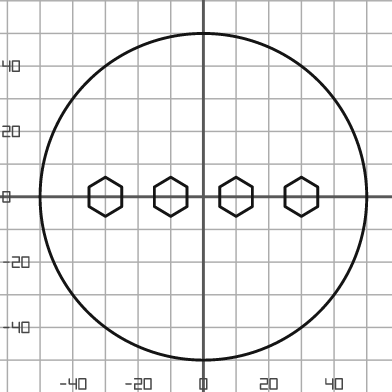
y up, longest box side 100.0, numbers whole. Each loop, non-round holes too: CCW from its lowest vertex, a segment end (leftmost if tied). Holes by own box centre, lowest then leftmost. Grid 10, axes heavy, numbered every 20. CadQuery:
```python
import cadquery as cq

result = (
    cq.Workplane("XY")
    .moveTo(0.0, 0.0)
    .circle(50.0)
    .moveTo(-30.0, -6.0)
    .lineTo(-25.0, -3.0)
    .lineTo(-25.0, 3.0)
    .lineTo(-30.0, 6.0)
    .lineTo(-35.0, 3.0)
    .lineTo(-35.0, -3.0)
    .close()
    .moveTo(-10.0, -6.0)
    .lineTo(-5.0, -3.0)
    .lineTo(-5.0, 3.0)
    .lineTo(-10.0, 6.0)
    .lineTo(-15.0, 3.0)
    .lineTo(-15.0, -3.0)
    .close()
    .moveTo(10.0, -6.0)
    .lineTo(15.0, -3.0)
    .lineTo(15.0, 3.0)
    .lineTo(10.0, 6.0)
    .lineTo(5.0, 3.0)
    .lineTo(5.0, -3.0)
    .close()
    .moveTo(30.0, -6.0)
    .lineTo(35.0, -3.0)
    .lineTo(35.0, 3.0)
    .lineTo(30.0, 6.0)
    .lineTo(25.0, 3.0)
    .lineTo(25.0, -3.0)
    .close()
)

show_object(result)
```